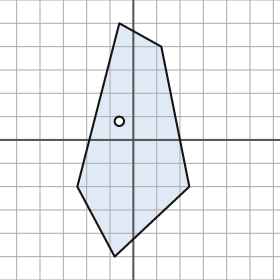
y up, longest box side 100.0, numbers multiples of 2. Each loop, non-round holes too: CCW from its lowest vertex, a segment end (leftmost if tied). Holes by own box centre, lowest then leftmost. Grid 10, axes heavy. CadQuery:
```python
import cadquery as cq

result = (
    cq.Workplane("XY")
    .moveTo(-8.0, -50.0)
    .lineTo(24.0, -20.0)
    .lineTo(12.0, 40.0)
    .lineTo(-6.0, 50.0)
    .lineTo(-24.0, -20.0)
    .close()
    .moveTo(-6.0, 8.0)
    .circle(2.0)
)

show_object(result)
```